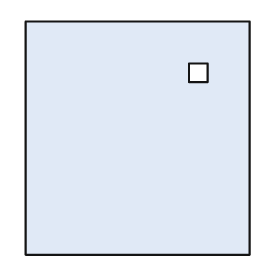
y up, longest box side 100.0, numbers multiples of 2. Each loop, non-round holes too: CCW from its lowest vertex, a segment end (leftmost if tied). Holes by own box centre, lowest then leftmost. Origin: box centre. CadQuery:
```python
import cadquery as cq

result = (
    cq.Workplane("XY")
    .moveTo(-48.0, -50.0)
    .lineTo(48.0, -50.0)
    .lineTo(48.0, 50.0)
    .lineTo(-48.0, 50.0)
    .close()
    .moveTo(22.0, 24.0)
    .lineTo(30.0, 24.0)
    .lineTo(30.0, 32.0)
    .lineTo(22.0, 32.0)
    .close()
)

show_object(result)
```